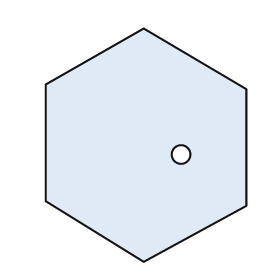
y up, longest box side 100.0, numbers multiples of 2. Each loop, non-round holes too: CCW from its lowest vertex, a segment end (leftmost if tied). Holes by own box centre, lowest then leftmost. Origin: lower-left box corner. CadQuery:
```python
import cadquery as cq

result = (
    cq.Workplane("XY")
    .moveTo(42.0, 0.0)
    .lineTo(86.0, 24.0)
    .lineTo(86.0, 74.0)
    .lineTo(42.0, 100.0)
    .lineTo(0.0, 76.0)
    .lineTo(0.0, 26.0)
    .close()
    .moveTo(58.0, 46.0)
    .circle(4.0)
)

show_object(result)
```